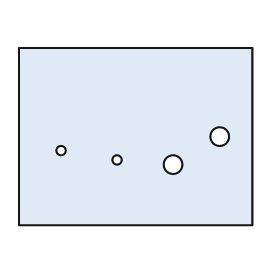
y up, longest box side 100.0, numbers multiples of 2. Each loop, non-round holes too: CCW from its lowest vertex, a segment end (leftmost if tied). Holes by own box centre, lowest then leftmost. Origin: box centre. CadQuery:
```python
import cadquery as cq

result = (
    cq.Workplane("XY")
    .moveTo(-50.0, -38.0)
    .lineTo(50.0, -38.0)
    .lineTo(50.0, 38.0)
    .lineTo(-50.0, 38.0)
    .close()
    .moveTo(16.0, -12.0)
    .circle(4.0)
    .moveTo(-8.0, -10.0)
    .circle(2.0)
    .moveTo(-32.0, -6.0)
    .circle(2.0)
    .moveTo(36.0, 0.0)
    .circle(4.0)
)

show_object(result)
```